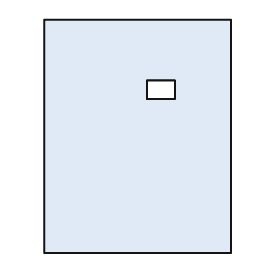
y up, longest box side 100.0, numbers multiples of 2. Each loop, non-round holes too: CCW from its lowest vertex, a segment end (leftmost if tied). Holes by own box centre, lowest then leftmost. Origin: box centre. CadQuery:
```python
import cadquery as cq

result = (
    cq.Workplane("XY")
    .moveTo(-40.0, -50.0)
    .lineTo(40.0, -50.0)
    .lineTo(40.0, 50.0)
    .lineTo(-40.0, 50.0)
    .close()
    .moveTo(4.0, 16.0)
    .lineTo(16.0, 16.0)
    .lineTo(16.0, 24.0)
    .lineTo(4.0, 24.0)
    .close()
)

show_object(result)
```